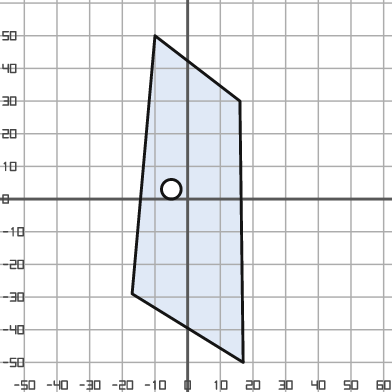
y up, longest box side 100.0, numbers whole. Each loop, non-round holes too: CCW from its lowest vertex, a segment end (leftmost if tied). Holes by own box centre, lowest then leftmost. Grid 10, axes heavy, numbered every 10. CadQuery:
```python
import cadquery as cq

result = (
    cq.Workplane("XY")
    .moveTo(17.0, -50.0)
    .lineTo(16.0, 30.0)
    .lineTo(-10.0, 50.0)
    .lineTo(-17.0, -29.0)
    .close()
    .moveTo(-5.0, 3.0)
    .circle(3.0)
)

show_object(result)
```